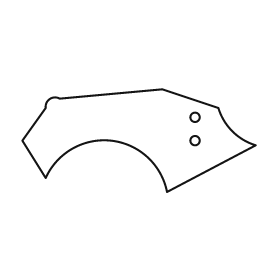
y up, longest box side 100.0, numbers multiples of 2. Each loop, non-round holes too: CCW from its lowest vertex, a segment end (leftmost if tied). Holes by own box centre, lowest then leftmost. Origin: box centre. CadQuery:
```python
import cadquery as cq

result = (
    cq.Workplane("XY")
    .moveTo(12.0, -22.0)
    .lineTo(50.0, -2.0)
    .threePointArc((40.0, 4.0), (34.0, 14.0))
    .lineTo(10.0, 22.0)
    .lineTo(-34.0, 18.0)
    .threePointArc((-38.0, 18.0), (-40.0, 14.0))
    .lineTo(-50.0, 0.0)
    .lineTo(-40.0, -16.0)
    .threePointArc((-12.0, 0.0), (12.0, -22.0))
    .close()
    .moveTo(24.0, 0.0)
    .circle(2.0)
    .moveTo(24.0, 10.0)
    .circle(2.0)
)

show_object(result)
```